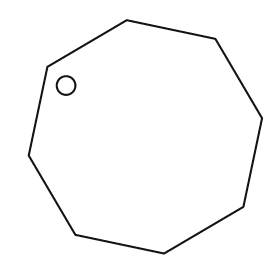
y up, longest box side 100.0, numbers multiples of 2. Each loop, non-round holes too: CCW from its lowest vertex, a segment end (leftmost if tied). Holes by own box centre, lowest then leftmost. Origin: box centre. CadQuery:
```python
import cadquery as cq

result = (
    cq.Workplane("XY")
    .moveTo(8.0, -50.0)
    .lineTo(42.0, -30.0)
    .lineTo(50.0, 8.0)
    .lineTo(30.0, 42.0)
    .lineTo(-8.0, 50.0)
    .lineTo(-42.0, 30.0)
    .lineTo(-50.0, -8.0)
    .lineTo(-30.0, -42.0)
    .close()
    .moveTo(-34.0, 22.0)
    .circle(4.0)
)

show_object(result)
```